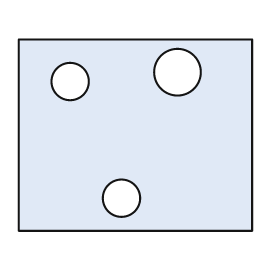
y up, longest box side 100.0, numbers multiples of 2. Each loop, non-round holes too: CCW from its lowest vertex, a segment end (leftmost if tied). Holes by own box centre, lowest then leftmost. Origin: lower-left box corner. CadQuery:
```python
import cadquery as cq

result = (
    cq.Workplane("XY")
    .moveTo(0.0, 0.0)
    .lineTo(100.0, 0.0)
    .lineTo(100.0, 82.0)
    .lineTo(0.0, 82.0)
    .close()
    .moveTo(44.0, 14.0)
    .circle(8.0)
    .moveTo(22.0, 64.0)
    .circle(8.0)
    .moveTo(68.0, 68.0)
    .circle(10.0)
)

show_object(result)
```